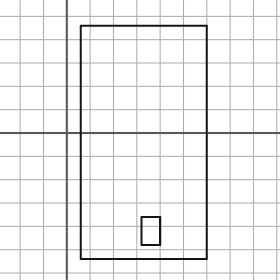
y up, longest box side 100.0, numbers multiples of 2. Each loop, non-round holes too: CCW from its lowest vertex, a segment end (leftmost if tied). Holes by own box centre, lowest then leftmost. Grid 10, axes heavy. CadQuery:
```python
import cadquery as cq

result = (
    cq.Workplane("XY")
    .moveTo(6.0, -54.0)
    .lineTo(60.0, -54.0)
    .lineTo(60.0, 46.0)
    .lineTo(6.0, 46.0)
    .close()
    .moveTo(32.0, -48.0)
    .lineTo(40.0, -48.0)
    .lineTo(40.0, -36.0)
    .lineTo(32.0, -36.0)
    .close()
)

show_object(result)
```